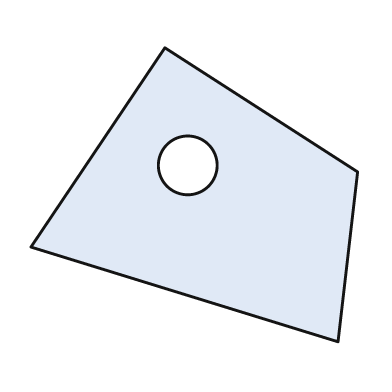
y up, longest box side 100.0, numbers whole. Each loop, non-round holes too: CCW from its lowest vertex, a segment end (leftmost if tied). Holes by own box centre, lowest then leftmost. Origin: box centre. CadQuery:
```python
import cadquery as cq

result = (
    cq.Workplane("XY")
    .moveTo(44.0, -45.0)
    .lineTo(50.0, 7.0)
    .lineTo(-9.0, 45.0)
    .lineTo(-50.0, -16.0)
    .close()
    .moveTo(-2.0, 9.0)
    .circle(9.0)
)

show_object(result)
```